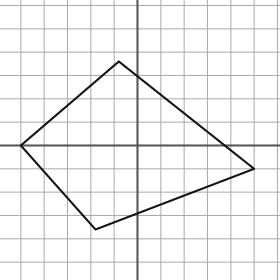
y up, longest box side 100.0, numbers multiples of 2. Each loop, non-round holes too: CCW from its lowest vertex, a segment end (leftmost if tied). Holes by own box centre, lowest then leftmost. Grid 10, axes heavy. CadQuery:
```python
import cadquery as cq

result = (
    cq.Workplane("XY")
    .moveTo(-18.0, -36.0)
    .lineTo(50.0, -10.0)
    .lineTo(-8.0, 36.0)
    .lineTo(-50.0, 0.0)
    .close()
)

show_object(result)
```